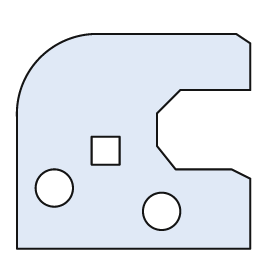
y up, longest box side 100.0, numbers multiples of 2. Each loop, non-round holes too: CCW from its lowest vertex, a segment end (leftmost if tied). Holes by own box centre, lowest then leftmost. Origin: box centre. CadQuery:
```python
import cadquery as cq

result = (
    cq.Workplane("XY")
    .moveTo(-50.0, -46.0)
    .lineTo(50.0, -46.0)
    .lineTo(50.0, -16.0)
    .lineTo(42.0, -12.0)
    .lineTo(18.0, -12.0)
    .lineTo(10.0, -2.0)
    .lineTo(10.0, 12.0)
    .lineTo(20.0, 22.0)
    .lineTo(50.0, 22.0)
    .lineTo(50.0, 42.0)
    .lineTo(44.0, 46.0)
    .lineTo(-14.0, 46.0)
    .threePointArc((-40.0, 36.0), (-50.0, 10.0))
    .close()
    .moveTo(12.0, -30.0)
    .circle(8.0)
    .moveTo(-34.0, -20.0)
    .circle(8.0)
    .moveTo(-18.0, -10.0)
    .lineTo(-6.0, -10.0)
    .lineTo(-6.0, 2.0)
    .lineTo(-18.0, 2.0)
    .close()
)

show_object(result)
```